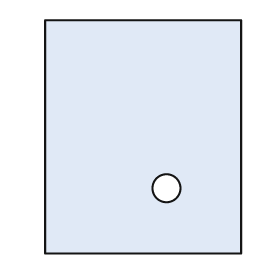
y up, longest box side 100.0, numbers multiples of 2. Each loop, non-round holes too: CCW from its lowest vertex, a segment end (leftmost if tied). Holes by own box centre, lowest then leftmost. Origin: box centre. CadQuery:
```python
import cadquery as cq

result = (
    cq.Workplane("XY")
    .moveTo(-42.0, -50.0)
    .lineTo(42.0, -50.0)
    .lineTo(42.0, 50.0)
    .lineTo(-42.0, 50.0)
    .close()
    .moveTo(10.0, -22.0)
    .circle(6.0)
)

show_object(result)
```